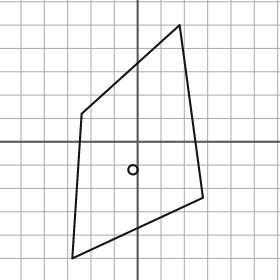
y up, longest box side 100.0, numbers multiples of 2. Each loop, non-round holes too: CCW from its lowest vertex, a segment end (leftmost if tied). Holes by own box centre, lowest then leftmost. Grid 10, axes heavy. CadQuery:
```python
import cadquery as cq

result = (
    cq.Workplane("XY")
    .moveTo(-28.0, -50.0)
    .lineTo(28.0, -24.0)
    .lineTo(18.0, 50.0)
    .lineTo(-24.0, 12.0)
    .close()
    .moveTo(-2.0, -12.0)
    .circle(2.0)
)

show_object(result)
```